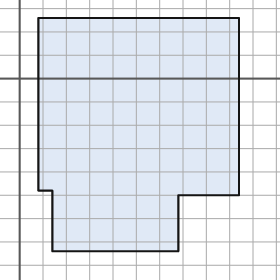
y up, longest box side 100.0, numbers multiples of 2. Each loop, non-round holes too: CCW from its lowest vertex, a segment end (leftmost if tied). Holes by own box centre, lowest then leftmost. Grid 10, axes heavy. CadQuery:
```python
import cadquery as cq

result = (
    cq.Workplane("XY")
    .moveTo(14.0, -74.0)
    .lineTo(68.0, -74.0)
    .lineTo(68.0, -50.0)
    .lineTo(94.0, -50.0)
    .lineTo(94.0, 26.0)
    .lineTo(8.0, 26.0)
    .lineTo(8.0, -48.0)
    .lineTo(14.0, -48.0)
    .close()
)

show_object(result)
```